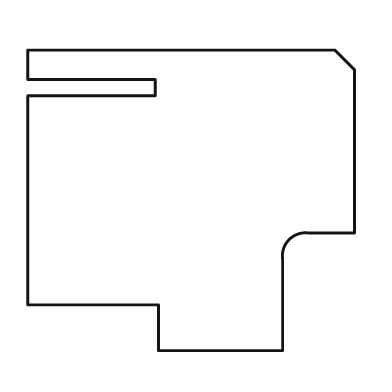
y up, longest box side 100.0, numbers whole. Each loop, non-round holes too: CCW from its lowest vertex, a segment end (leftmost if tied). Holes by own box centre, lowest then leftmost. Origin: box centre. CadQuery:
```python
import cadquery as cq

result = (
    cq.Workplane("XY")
    .moveTo(-10.0, -46.0)
    .lineTo(28.0, -46.0)
    .lineTo(28.0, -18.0)
    .threePointArc((30.0, -12.0), (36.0, -10.0))
    .lineTo(50.0, -10.0)
    .lineTo(50.0, 40.0)
    .lineTo(44.0, 46.0)
    .lineTo(-50.0, 46.0)
    .lineTo(-50.0, 37.0)
    .lineTo(-11.0, 37.0)
    .lineTo(-11.0, 32.0)
    .lineTo(-50.0, 32.0)
    .lineTo(-50.0, -32.0)
    .lineTo(-10.0, -32.0)
    .close()
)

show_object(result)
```